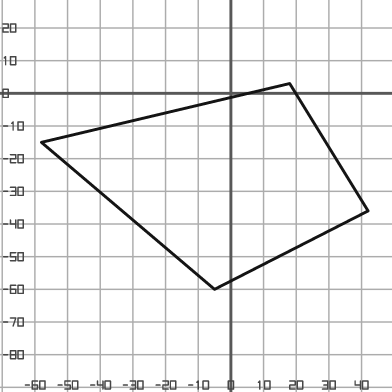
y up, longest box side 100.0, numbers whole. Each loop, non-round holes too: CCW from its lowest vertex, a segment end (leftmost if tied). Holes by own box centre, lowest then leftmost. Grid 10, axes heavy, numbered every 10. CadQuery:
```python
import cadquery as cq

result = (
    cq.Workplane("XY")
    .moveTo(-5.0, -60.0)
    .lineTo(42.0, -36.0)
    .lineTo(18.0, 3.0)
    .lineTo(-58.0, -15.0)
    .close()
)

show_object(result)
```